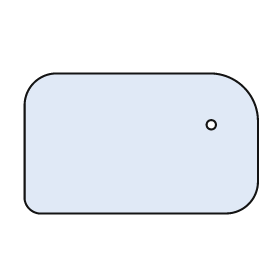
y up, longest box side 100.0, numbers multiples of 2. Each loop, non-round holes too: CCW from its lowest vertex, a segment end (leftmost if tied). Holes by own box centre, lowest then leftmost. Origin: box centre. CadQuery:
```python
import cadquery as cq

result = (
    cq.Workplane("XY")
    .moveTo(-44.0, -30.0)
    .lineTo(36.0, -30.0)
    .threePointArc((46.0, -26.0), (50.0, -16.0))
    .lineTo(50.0, 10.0)
    .threePointArc((44.0, 24.0), (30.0, 30.0))
    .lineTo(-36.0, 30.0)
    .threePointArc((-46.0, 26.0), (-50.0, 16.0))
    .lineTo(-50.0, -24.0)
    .threePointArc((-48.0, -28.0), (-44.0, -30.0))
    .close()
    .moveTo(30.0, 8.0)
    .circle(2.0)
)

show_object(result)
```